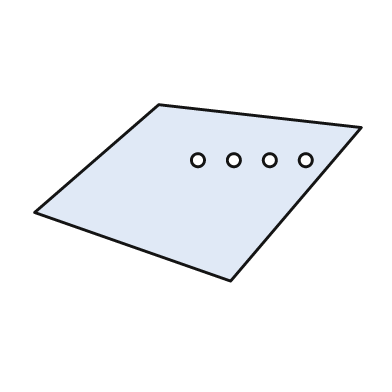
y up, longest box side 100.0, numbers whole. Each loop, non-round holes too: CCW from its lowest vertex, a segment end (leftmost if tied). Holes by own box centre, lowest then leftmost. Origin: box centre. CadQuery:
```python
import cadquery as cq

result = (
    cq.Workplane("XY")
    .moveTo(10.0, -27.0)
    .lineTo(50.0, 20.0)
    .lineTo(-12.0, 27.0)
    .lineTo(-50.0, -6.0)
    .close()
    .moveTo(0.0, 10.0)
    .circle(2.0)
    .moveTo(11.0, 10.0)
    .circle(2.0)
    .moveTo(22.0, 10.0)
    .circle(2.0)
    .moveTo(33.0, 10.0)
    .circle(2.0)
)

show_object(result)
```